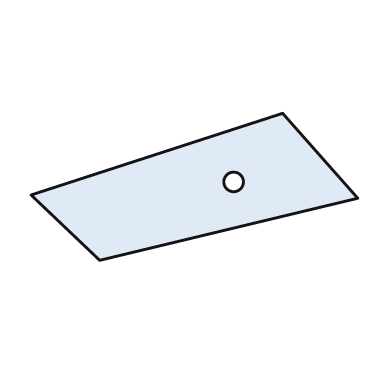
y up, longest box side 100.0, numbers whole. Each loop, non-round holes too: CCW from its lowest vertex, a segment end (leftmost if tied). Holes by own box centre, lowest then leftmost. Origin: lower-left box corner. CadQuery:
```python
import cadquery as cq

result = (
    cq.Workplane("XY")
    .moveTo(21.0, 0.0)
    .lineTo(100.0, 19.0)
    .lineTo(77.0, 45.0)
    .lineTo(0.0, 20.0)
    .close()
    .moveTo(62.0, 24.0)
    .circle(3.0)
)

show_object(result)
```